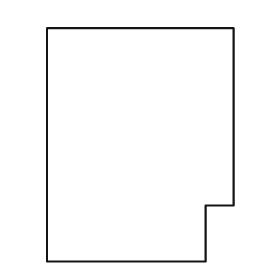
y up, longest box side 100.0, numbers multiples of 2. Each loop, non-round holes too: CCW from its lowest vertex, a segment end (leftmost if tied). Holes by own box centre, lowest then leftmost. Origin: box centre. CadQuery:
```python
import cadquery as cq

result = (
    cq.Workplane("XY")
    .moveTo(-40.0, -50.0)
    .lineTo(28.0, -50.0)
    .lineTo(28.0, -26.0)
    .lineTo(40.0, -26.0)
    .lineTo(40.0, 50.0)
    .lineTo(-40.0, 50.0)
    .close()
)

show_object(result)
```